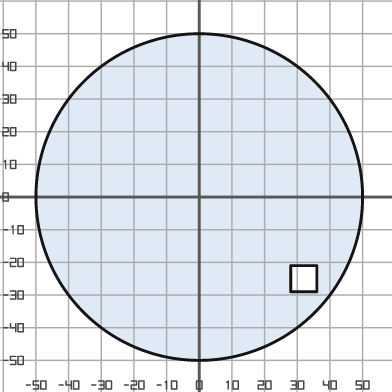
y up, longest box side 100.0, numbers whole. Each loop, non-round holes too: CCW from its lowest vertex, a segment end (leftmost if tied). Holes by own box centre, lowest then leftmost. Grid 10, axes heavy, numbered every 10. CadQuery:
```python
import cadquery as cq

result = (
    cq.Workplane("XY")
    .moveTo(0.0, 0.0)
    .circle(50.0)
    .moveTo(28.0, -29.0)
    .lineTo(36.0, -29.0)
    .lineTo(36.0, -21.0)
    .lineTo(28.0, -21.0)
    .close()
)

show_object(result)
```